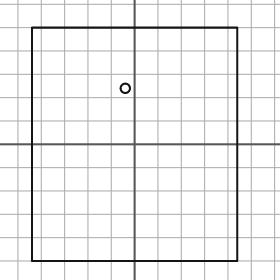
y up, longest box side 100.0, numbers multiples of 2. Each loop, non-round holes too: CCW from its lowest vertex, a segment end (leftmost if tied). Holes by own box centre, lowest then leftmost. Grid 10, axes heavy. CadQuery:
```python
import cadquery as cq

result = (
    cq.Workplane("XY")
    .moveTo(-44.0, -50.0)
    .lineTo(44.0, -50.0)
    .lineTo(44.0, 50.0)
    .lineTo(-44.0, 50.0)
    .close()
    .moveTo(-4.0, 24.0)
    .circle(2.0)
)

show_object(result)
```